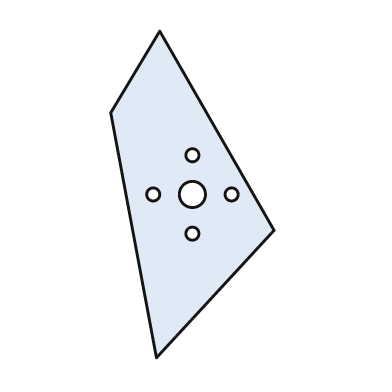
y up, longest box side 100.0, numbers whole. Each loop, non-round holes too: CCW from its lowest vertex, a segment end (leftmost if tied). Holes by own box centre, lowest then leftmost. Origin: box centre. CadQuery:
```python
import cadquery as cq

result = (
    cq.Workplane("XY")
    .moveTo(-11.0, -50.0)
    .lineTo(25.0, -11.0)
    .lineTo(-10.0, 50.0)
    .lineTo(-25.0, 25.0)
    .close()
    .moveTo(0.0, -12.0)
    .circle(2.0)
    .moveTo(-12.0, 0.0)
    .circle(2.0)
    .moveTo(0.0, 0.0)
    .circle(4.0)
    .moveTo(12.0, 0.0)
    .circle(2.0)
    .moveTo(0.0, 12.0)
    .circle(2.0)
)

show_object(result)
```